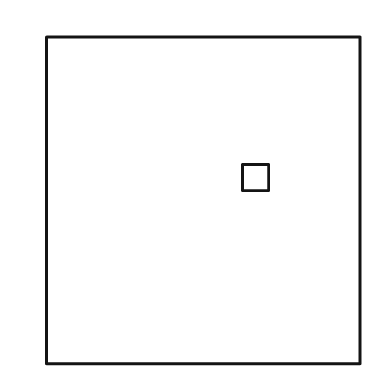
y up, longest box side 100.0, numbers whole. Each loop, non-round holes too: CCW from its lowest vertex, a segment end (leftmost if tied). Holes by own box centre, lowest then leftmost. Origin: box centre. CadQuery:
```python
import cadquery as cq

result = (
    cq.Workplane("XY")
    .moveTo(-48.0, -50.0)
    .lineTo(48.0, -50.0)
    .lineTo(48.0, 50.0)
    .lineTo(-48.0, 50.0)
    .close()
    .moveTo(12.0, 3.0)
    .lineTo(20.0, 3.0)
    .lineTo(20.0, 11.0)
    .lineTo(12.0, 11.0)
    .close()
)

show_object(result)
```